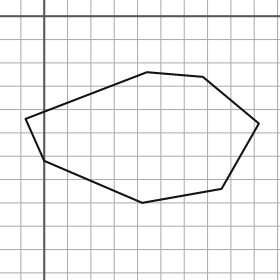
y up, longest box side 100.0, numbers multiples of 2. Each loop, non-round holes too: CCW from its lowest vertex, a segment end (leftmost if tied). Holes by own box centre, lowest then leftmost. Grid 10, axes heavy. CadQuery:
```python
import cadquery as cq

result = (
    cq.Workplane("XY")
    .moveTo(42.0, -80.0)
    .lineTo(76.0, -74.0)
    .lineTo(92.0, -46.0)
    .lineTo(68.0, -26.0)
    .lineTo(44.0, -24.0)
    .lineTo(-8.0, -44.0)
    .lineTo(0.0, -62.0)
    .close()
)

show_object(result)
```